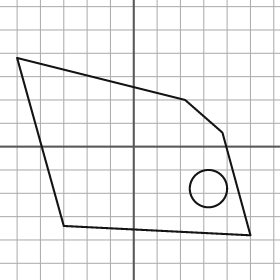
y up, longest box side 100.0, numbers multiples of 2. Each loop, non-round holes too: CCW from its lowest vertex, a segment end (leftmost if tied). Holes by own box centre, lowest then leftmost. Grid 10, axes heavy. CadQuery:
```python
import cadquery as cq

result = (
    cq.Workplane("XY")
    .moveTo(50.0, -38.0)
    .lineTo(38.0, 6.0)
    .lineTo(22.0, 20.0)
    .lineTo(-50.0, 38.0)
    .lineTo(-30.0, -34.0)
    .close()
    .moveTo(32.0, -18.0)
    .circle(8.0)
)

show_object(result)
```